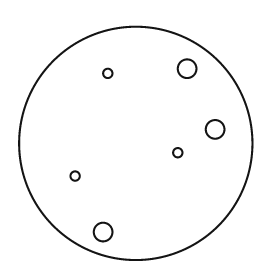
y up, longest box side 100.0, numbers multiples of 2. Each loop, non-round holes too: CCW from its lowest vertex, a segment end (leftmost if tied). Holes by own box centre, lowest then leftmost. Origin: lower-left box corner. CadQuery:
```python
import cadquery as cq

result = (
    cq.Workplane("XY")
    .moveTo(50.0, 50.0)
    .circle(50.0)
    .moveTo(36.0, 12.0)
    .circle(4.0)
    .moveTo(24.0, 36.0)
    .circle(2.0)
    .moveTo(68.0, 46.0)
    .circle(2.0)
    .moveTo(84.0, 56.0)
    .circle(4.0)
    .moveTo(38.0, 80.0)
    .circle(2.0)
    .moveTo(72.0, 82.0)
    .circle(4.0)
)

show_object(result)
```